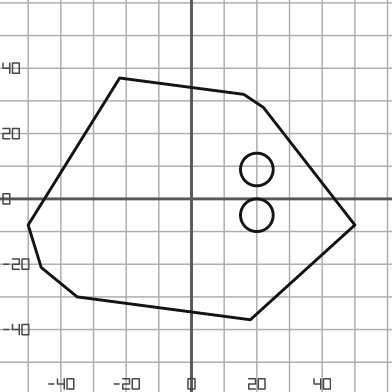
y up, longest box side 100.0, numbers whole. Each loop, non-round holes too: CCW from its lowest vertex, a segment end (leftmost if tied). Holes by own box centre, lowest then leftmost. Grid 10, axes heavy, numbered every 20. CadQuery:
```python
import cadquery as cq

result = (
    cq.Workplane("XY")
    .moveTo(18.0, -37.0)
    .lineTo(50.0, -8.0)
    .lineTo(22.0, 28.0)
    .lineTo(16.0, 32.0)
    .lineTo(-22.0, 37.0)
    .lineTo(-50.0, -8.0)
    .lineTo(-46.0, -21.0)
    .lineTo(-35.0, -30.0)
    .close()
    .moveTo(20.0, -5.0)
    .circle(5.0)
    .moveTo(20.0, 9.0)
    .circle(5.0)
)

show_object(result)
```